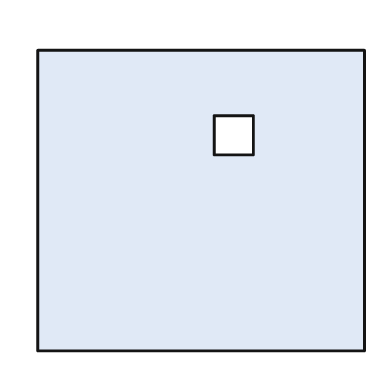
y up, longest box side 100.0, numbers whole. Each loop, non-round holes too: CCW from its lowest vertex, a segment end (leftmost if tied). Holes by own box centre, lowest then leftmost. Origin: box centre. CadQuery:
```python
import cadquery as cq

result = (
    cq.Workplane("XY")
    .moveTo(-50.0, -46.0)
    .lineTo(50.0, -46.0)
    .lineTo(50.0, 46.0)
    .lineTo(-50.0, 46.0)
    .close()
    .moveTo(4.0, 14.0)
    .lineTo(16.0, 14.0)
    .lineTo(16.0, 26.0)
    .lineTo(4.0, 26.0)
    .close()
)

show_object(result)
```